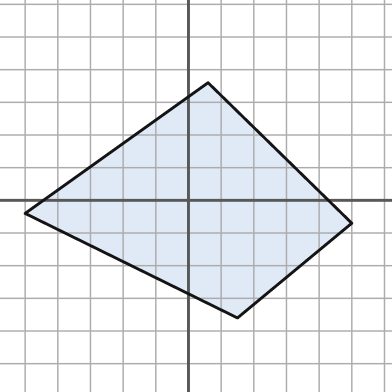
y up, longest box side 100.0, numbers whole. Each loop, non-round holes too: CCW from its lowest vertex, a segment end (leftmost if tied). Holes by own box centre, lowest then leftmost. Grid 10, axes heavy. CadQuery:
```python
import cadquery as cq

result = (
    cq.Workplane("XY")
    .moveTo(15.0, -36.0)
    .lineTo(50.0, -7.0)
    .lineTo(6.0, 36.0)
    .lineTo(-50.0, -4.0)
    .close()
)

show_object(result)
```